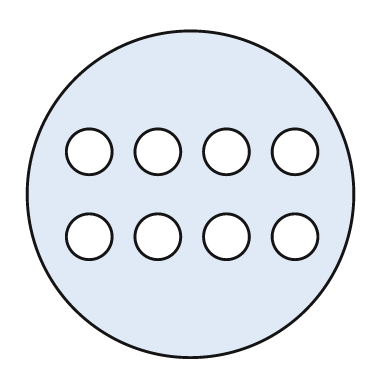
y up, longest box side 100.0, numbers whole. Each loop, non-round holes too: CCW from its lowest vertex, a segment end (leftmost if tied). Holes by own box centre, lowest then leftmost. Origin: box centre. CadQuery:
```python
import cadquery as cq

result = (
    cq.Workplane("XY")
    .moveTo(0.0, 0.0)
    .circle(50.0)
    .moveTo(-31.0, -13.0)
    .circle(7.0)
    .moveTo(-10.0, -13.0)
    .circle(7.0)
    .moveTo(11.0, -13.0)
    .circle(7.0)
    .moveTo(32.0, -13.0)
    .circle(7.0)
    .moveTo(-31.0, 13.0)
    .circle(7.0)
    .moveTo(-10.0, 13.0)
    .circle(7.0)
    .moveTo(11.0, 13.0)
    .circle(7.0)
    .moveTo(32.0, 13.0)
    .circle(7.0)
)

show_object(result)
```